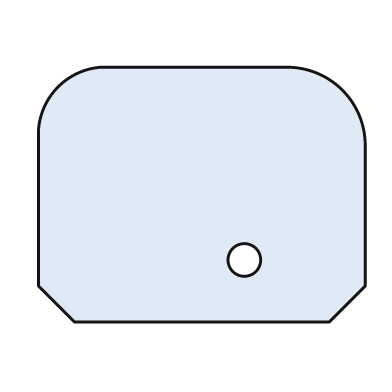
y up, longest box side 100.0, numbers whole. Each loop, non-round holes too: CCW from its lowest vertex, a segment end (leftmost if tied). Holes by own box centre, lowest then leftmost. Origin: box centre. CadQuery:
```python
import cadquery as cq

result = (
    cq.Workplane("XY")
    .moveTo(-39.0, -39.0)
    .lineTo(39.0, -39.0)
    .lineTo(50.0, -28.0)
    .lineTo(50.0, 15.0)
    .threePointArc((43.0, 32.0), (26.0, 39.0))
    .lineTo(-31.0, 39.0)
    .threePointArc((-44.0, 33.0), (-50.0, 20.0))
    .lineTo(-50.0, -28.0)
    .close()
    .moveTo(13.0, -20.0)
    .circle(5.0)
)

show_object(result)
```